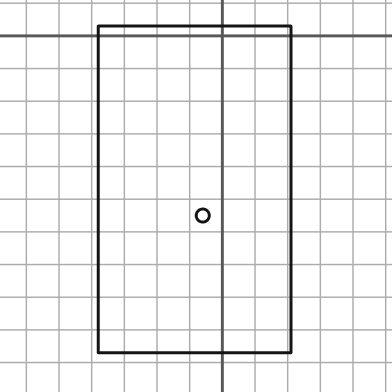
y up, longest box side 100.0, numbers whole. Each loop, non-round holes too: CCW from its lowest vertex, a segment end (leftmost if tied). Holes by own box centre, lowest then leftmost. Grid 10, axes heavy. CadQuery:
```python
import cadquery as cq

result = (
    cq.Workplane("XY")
    .moveTo(-38.0, -97.0)
    .lineTo(21.0, -97.0)
    .lineTo(21.0, 3.0)
    .lineTo(-38.0, 3.0)
    .close()
    .moveTo(-6.0, -55.0)
    .circle(2.0)
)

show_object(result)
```